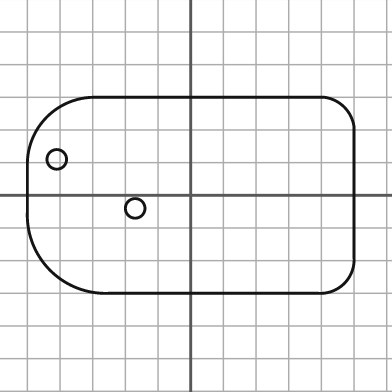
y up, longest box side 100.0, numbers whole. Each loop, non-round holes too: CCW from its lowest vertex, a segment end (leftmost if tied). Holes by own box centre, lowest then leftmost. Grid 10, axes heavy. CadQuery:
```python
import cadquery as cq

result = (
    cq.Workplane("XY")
    .moveTo(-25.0, -30.0)
    .lineTo(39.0, -30.0)
    .threePointArc((47.0, -27.0), (50.0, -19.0))
    .lineTo(50.0, 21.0)
    .threePointArc((47.0, 27.0), (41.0, 30.0))
    .lineTo(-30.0, 30.0)
    .threePointArc((-44.0, 24.0), (-50.0, 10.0))
    .lineTo(-50.0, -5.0)
    .threePointArc((-43.0, -23.0), (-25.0, -30.0))
    .close()
    .moveTo(-17.0, -4.0)
    .circle(3.0)
    .moveTo(-41.0, 11.0)
    .circle(3.0)
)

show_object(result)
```